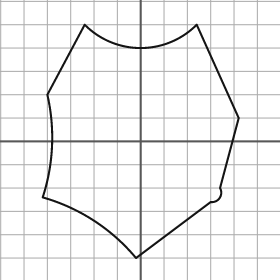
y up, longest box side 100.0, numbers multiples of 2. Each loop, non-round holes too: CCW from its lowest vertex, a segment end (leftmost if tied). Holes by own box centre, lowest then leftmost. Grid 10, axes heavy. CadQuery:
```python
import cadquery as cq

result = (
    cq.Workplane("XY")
    .moveTo(-2.0, -50.0)
    .lineTo(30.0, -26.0)
    .threePointArc((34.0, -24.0), (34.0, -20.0))
    .lineTo(42.0, 10.0)
    .lineTo(24.0, 50.0)
    .threePointArc((0.0, 40.0), (-24.0, 50.0))
    .lineTo(-40.0, 20.0)
    .threePointArc((-38.0, -2.0), (-42.0, -24.0))
    .threePointArc((-20.0, -34.0), (-2.0, -50.0))
    .close()
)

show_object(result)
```